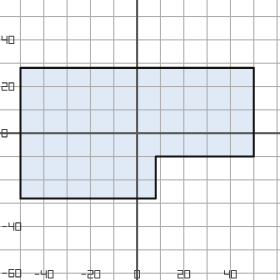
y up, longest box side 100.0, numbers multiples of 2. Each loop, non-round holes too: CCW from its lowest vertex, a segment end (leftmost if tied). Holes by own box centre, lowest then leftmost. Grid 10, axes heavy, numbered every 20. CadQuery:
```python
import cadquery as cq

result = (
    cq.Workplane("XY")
    .moveTo(-50.0, -28.0)
    .lineTo(8.0, -28.0)
    .lineTo(8.0, -10.0)
    .lineTo(50.0, -10.0)
    .lineTo(50.0, 28.0)
    .lineTo(-50.0, 28.0)
    .close()
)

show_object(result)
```